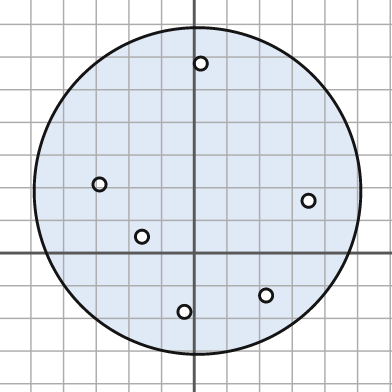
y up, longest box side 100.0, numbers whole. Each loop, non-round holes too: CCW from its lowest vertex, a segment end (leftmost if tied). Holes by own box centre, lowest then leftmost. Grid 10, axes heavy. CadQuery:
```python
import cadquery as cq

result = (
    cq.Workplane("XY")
    .moveTo(1.0, 19.0)
    .circle(50.0)
    .moveTo(-3.0, -18.0)
    .circle(2.0)
    .moveTo(22.0, -13.0)
    .circle(2.0)
    .moveTo(-16.0, 5.0)
    .circle(2.0)
    .moveTo(35.0, 16.0)
    .circle(2.0)
    .moveTo(-29.0, 21.0)
    .circle(2.0)
    .moveTo(2.0, 58.0)
    .circle(2.0)
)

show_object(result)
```